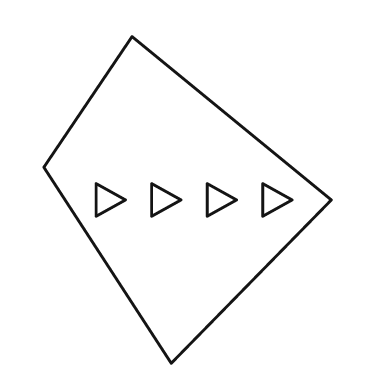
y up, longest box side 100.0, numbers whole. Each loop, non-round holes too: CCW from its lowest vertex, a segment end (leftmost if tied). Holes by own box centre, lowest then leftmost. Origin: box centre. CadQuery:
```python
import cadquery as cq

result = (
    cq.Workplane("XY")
    .moveTo(-5.0, -50.0)
    .lineTo(44.0, 0.0)
    .lineTo(-17.0, 50.0)
    .lineTo(-44.0, 10.0)
    .close()
    .moveTo(-28.0, -5.0)
    .lineTo(-19.0, 0.0)
    .lineTo(-28.0, 5.0)
    .close()
    .moveTo(-11.0, -5.0)
    .lineTo(-2.0, 0.0)
    .lineTo(-11.0, 5.0)
    .close()
    .moveTo(6.0, -5.0)
    .lineTo(15.0, 0.0)
    .lineTo(6.0, 5.0)
    .close()
    .moveTo(23.0, -5.0)
    .lineTo(32.0, 0.0)
    .lineTo(23.0, 5.0)
    .close()
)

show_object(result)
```